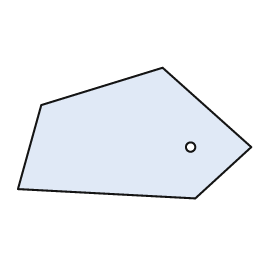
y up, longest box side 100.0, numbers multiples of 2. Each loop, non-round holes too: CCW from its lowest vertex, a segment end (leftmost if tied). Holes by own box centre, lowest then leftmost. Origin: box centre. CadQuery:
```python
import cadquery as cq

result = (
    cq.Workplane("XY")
    .moveTo(26.0, -28.0)
    .lineTo(50.0, -6.0)
    .lineTo(12.0, 28.0)
    .lineTo(-40.0, 12.0)
    .lineTo(-50.0, -24.0)
    .close()
    .moveTo(24.0, -6.0)
    .circle(2.0)
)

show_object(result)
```